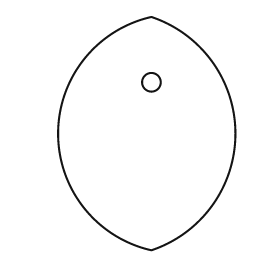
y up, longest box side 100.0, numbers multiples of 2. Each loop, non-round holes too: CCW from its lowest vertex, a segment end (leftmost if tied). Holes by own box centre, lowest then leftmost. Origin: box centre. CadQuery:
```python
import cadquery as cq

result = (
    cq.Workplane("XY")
    .moveTo(2.0, -50.0)
    .threePointArc((38.0, 0.0), (2.0, 50.0))
    .threePointArc((-38.0, 0.0), (2.0, -50.0))
    .close()
    .moveTo(2.0, 22.0)
    .circle(4.0)
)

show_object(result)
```